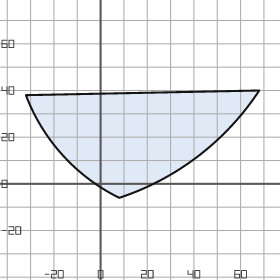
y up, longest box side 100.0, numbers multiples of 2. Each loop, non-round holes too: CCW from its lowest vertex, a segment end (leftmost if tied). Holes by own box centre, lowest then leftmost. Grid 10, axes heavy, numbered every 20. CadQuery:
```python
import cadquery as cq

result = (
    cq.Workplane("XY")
    .moveTo(8.0, -6.0)
    .threePointArc((42.0, 12.0), (68.0, 40.0))
    .lineTo(-32.0, 38.0)
    .threePointArc((-16.0, 12.0), (8.0, -6.0))
    .close()
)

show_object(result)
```